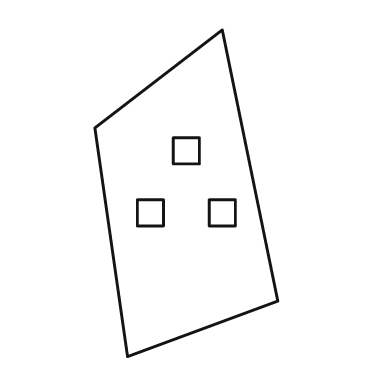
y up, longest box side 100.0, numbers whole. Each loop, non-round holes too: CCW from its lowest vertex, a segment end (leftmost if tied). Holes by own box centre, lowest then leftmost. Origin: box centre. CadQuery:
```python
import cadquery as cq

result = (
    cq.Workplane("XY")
    .moveTo(-18.0, -50.0)
    .lineTo(28.0, -33.0)
    .lineTo(11.0, 50.0)
    .lineTo(-28.0, 20.0)
    .close()
    .moveTo(-15.0, -10.0)
    .lineTo(-7.0, -10.0)
    .lineTo(-7.0, -2.0)
    .lineTo(-15.0, -2.0)
    .close()
    .moveTo(7.0, -10.0)
    .lineTo(15.0, -10.0)
    .lineTo(15.0, -2.0)
    .lineTo(7.0, -2.0)
    .close()
    .moveTo(-4.0, 9.0)
    .lineTo(4.0, 9.0)
    .lineTo(4.0, 17.0)
    .lineTo(-4.0, 17.0)
    .close()
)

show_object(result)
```